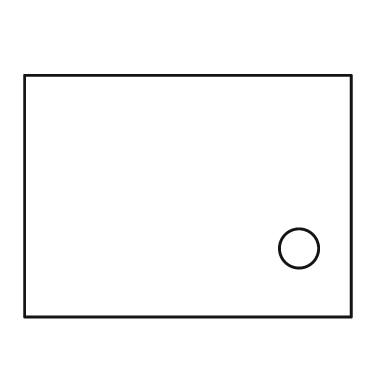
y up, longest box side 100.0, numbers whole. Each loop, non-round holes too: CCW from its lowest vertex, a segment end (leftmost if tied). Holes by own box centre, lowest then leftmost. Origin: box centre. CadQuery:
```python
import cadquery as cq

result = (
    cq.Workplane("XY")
    .moveTo(-50.0, -37.0)
    .lineTo(50.0, -37.0)
    .lineTo(50.0, 37.0)
    .lineTo(-50.0, 37.0)
    .close()
    .moveTo(34.0, -16.0)
    .circle(6.0)
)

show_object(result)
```